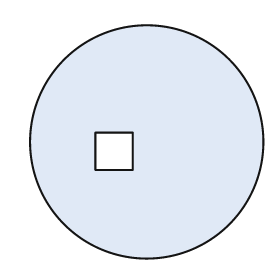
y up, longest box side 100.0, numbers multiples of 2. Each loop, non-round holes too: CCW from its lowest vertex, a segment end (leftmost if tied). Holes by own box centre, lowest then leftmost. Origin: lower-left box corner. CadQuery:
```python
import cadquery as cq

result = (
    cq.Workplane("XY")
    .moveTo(50.0, 50.0)
    .circle(50.0)
    .moveTo(28.0, 38.0)
    .lineTo(44.0, 38.0)
    .lineTo(44.0, 54.0)
    .lineTo(28.0, 54.0)
    .close()
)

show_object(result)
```